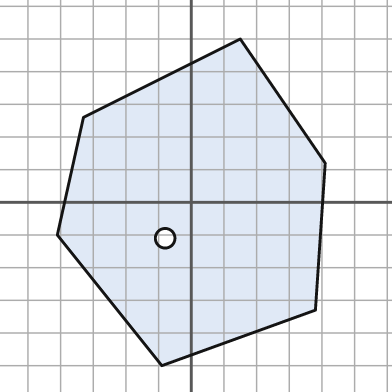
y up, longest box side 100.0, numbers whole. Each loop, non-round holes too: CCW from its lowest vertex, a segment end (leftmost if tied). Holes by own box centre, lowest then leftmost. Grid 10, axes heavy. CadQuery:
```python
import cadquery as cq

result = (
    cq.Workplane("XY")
    .moveTo(-9.0, -50.0)
    .lineTo(38.0, -33.0)
    .lineTo(41.0, 12.0)
    .lineTo(15.0, 50.0)
    .lineTo(-33.0, 26.0)
    .lineTo(-41.0, -10.0)
    .close()
    .moveTo(-8.0, -11.0)
    .circle(3.0)
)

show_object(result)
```